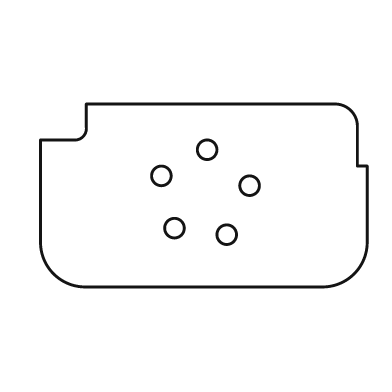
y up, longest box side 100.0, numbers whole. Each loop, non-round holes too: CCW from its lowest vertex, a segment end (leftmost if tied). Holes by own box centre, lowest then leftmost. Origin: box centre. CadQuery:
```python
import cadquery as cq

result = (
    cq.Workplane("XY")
    .moveTo(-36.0, -28.0)
    .lineTo(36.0, -28.0)
    .threePointArc((46.0, -24.0), (50.0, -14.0))
    .lineTo(50.0, 9.0)
    .lineTo(47.0, 9.0)
    .lineTo(47.0, 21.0)
    .threePointArc((45.0, 26.0), (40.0, 28.0))
    .lineTo(-36.0, 28.0)
    .lineTo(-36.0, 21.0)
    .threePointArc((-37.0, 18.0), (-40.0, 17.0))
    .lineTo(-50.0, 17.0)
    .lineTo(-50.0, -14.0)
    .threePointArc((-46.0, -24.0), (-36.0, -28.0))
    .close()
    .moveTo(7.0, -12.0)
    .circle(3.0)
    .moveTo(-9.0, -10.0)
    .circle(3.0)
    .moveTo(14.0, 3.0)
    .circle(3.0)
    .moveTo(-13.0, 6.0)
    .circle(3.0)
    .moveTo(1.0, 14.0)
    .circle(3.0)
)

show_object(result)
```